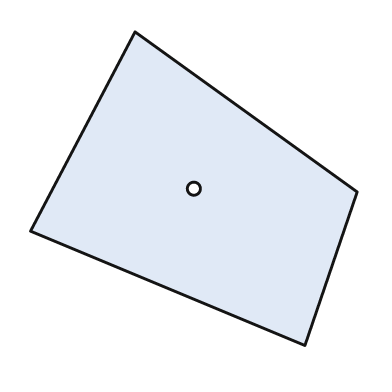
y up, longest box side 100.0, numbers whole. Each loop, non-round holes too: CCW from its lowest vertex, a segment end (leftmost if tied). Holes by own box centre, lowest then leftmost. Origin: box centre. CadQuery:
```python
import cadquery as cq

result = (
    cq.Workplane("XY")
    .moveTo(34.0, -48.0)
    .lineTo(50.0, -1.0)
    .lineTo(-18.0, 48.0)
    .lineTo(-50.0, -13.0)
    .close()
    .moveTo(0.0, 0.0)
    .circle(2.0)
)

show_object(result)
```